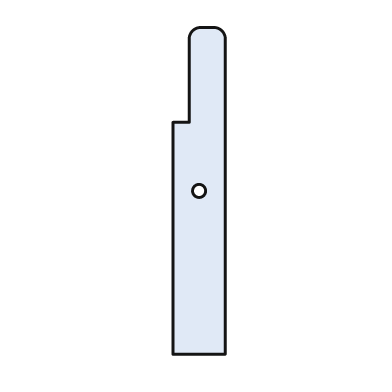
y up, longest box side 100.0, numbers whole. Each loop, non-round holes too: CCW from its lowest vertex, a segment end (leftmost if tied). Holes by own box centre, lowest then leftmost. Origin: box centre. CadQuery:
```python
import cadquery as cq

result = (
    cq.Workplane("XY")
    .moveTo(-8.0, -50.0)
    .lineTo(8.0, -50.0)
    .lineTo(8.0, 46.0)
    .threePointArc((7.0, 49.0), (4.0, 50.0))
    .lineTo(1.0, 50.0)
    .threePointArc((-2.0, 49.0), (-3.0, 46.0))
    .lineTo(-3.0, 21.0)
    .lineTo(-8.0, 21.0)
    .close()
    .moveTo(0.0, 0.0)
    .circle(2.0)
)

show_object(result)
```